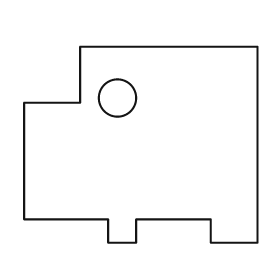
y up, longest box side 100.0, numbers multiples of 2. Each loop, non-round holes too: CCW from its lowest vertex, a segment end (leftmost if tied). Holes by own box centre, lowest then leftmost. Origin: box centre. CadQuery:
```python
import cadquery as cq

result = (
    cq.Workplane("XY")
    .moveTo(-14.0, -42.0)
    .lineTo(-2.0, -42.0)
    .lineTo(-2.0, -32.0)
    .lineTo(30.0, -32.0)
    .lineTo(30.0, -42.0)
    .lineTo(50.0, -42.0)
    .lineTo(50.0, 42.0)
    .lineTo(-26.0, 42.0)
    .lineTo(-26.0, 18.0)
    .lineTo(-50.0, 18.0)
    .lineTo(-50.0, -32.0)
    .lineTo(-14.0, -32.0)
    .close()
    .moveTo(-10.0, 20.0)
    .circle(8.0)
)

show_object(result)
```